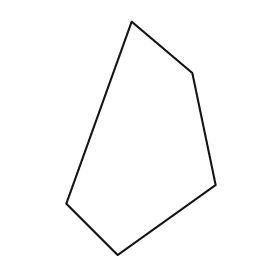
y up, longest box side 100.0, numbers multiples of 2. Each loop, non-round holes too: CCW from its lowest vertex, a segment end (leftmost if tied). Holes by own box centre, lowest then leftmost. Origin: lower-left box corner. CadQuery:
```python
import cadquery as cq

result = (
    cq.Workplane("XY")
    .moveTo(22.0, 0.0)
    .lineTo(64.0, 30.0)
    .lineTo(54.0, 78.0)
    .lineTo(28.0, 100.0)
    .lineTo(0.0, 22.0)
    .close()
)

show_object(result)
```